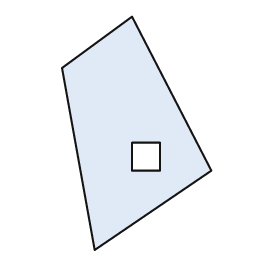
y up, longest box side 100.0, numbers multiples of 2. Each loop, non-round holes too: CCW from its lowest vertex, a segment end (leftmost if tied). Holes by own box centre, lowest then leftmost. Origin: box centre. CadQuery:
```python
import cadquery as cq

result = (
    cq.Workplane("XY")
    .moveTo(-18.0, -50.0)
    .lineTo(32.0, -16.0)
    .lineTo(-2.0, 50.0)
    .lineTo(-32.0, 28.0)
    .close()
    .moveTo(-2.0, -16.0)
    .lineTo(10.0, -16.0)
    .lineTo(10.0, -4.0)
    .lineTo(-2.0, -4.0)
    .close()
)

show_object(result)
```